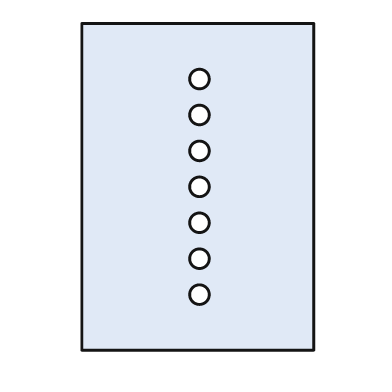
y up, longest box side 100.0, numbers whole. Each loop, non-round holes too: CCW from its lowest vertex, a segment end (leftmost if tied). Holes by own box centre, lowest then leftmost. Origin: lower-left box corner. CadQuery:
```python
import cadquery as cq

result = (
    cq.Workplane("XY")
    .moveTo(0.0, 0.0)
    .lineTo(71.0, 0.0)
    .lineTo(71.0, 100.0)
    .lineTo(0.0, 100.0)
    .close()
    .moveTo(36.0, 17.0)
    .circle(3.0)
    .moveTo(36.0, 28.0)
    .circle(3.0)
    .moveTo(36.0, 39.0)
    .circle(3.0)
    .moveTo(36.0, 50.0)
    .circle(3.0)
    .moveTo(36.0, 61.0)
    .circle(3.0)
    .moveTo(36.0, 72.0)
    .circle(3.0)
    .moveTo(36.0, 83.0)
    .circle(3.0)
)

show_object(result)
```